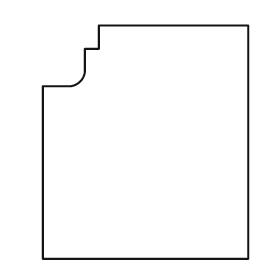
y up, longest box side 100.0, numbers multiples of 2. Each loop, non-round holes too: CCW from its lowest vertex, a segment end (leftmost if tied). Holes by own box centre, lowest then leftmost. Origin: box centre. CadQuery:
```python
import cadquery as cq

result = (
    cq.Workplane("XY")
    .moveTo(-44.0, -50.0)
    .lineTo(44.0, -50.0)
    .lineTo(44.0, 50.0)
    .lineTo(-20.0, 50.0)
    .lineTo(-20.0, 40.0)
    .lineTo(-26.0, 40.0)
    .lineTo(-26.0, 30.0)
    .threePointArc((-28.0, 26.0), (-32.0, 24.0))
    .lineTo(-44.0, 24.0)
    .close()
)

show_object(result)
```